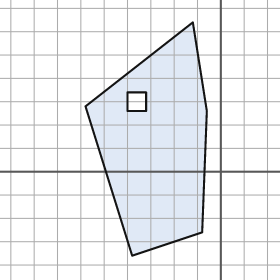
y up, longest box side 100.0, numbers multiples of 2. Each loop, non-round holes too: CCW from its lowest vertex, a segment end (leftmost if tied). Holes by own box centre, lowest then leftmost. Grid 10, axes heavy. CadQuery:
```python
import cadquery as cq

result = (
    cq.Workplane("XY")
    .moveTo(-38.0, -36.0)
    .lineTo(-8.0, -26.0)
    .lineTo(-6.0, 26.0)
    .lineTo(-12.0, 64.0)
    .lineTo(-58.0, 28.0)
    .close()
    .moveTo(-40.0, 26.0)
    .lineTo(-32.0, 26.0)
    .lineTo(-32.0, 34.0)
    .lineTo(-40.0, 34.0)
    .close()
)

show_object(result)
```